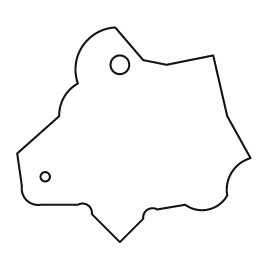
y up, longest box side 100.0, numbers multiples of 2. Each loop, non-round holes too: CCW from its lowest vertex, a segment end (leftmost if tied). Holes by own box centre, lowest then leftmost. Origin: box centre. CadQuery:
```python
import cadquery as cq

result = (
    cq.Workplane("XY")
    .moveTo(-6.0, -46.0)
    .lineTo(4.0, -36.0)
    .threePointArc((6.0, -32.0), (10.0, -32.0))
    .lineTo(22.0, -30.0)
    .threePointArc((32.0, -32.0), (40.0, -26.0))
    .threePointArc((42.0, -16.0), (50.0, -10.0))
    .lineTo(40.0, 8.0)
    .lineTo(34.0, 34.0)
    .lineTo(14.0, 30.0)
    .lineTo(4.0, 32.0)
    .lineTo(-8.0, 46.0)
    .threePointArc((-22.0, 38.0), (-24.0, 22.0))
    .threePointArc((-30.0, 16.0), (-32.0, 8.0))
    .lineTo(-50.0, -8.0)
    .lineTo(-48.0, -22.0)
    .threePointArc((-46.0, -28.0), (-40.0, -30.0))
    .lineTo(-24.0, -30.0)
    .threePointArc((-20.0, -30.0), (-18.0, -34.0))
    .close()
    .moveTo(-38.0, -18.0)
    .circle(2.0)
    .moveTo(-6.0, 30.0)
    .circle(4.0)
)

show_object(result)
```